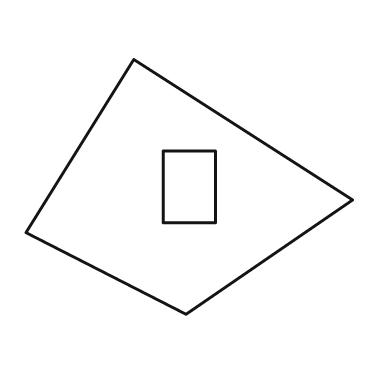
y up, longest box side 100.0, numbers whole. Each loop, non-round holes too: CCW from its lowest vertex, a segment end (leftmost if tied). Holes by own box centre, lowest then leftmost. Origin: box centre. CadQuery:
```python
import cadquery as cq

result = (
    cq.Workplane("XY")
    .moveTo(-1.0, -39.0)
    .lineTo(50.0, -4.0)
    .lineTo(-17.0, 39.0)
    .lineTo(-50.0, -14.0)
    .close()
    .moveTo(-8.0, -11.0)
    .lineTo(8.0, -11.0)
    .lineTo(8.0, 11.0)
    .lineTo(-8.0, 11.0)
    .close()
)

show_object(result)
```